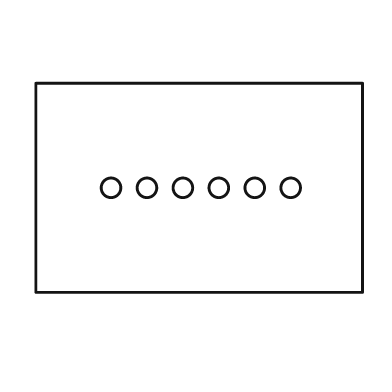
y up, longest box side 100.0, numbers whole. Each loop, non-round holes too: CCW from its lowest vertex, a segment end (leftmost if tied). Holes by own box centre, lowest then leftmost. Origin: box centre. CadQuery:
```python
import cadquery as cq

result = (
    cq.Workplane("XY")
    .moveTo(-50.0, -32.0)
    .lineTo(50.0, -32.0)
    .lineTo(50.0, 32.0)
    .lineTo(-50.0, 32.0)
    .close()
    .moveTo(-27.0, 0.0)
    .circle(3.0)
    .moveTo(-16.0, 0.0)
    .circle(3.0)
    .moveTo(-5.0, 0.0)
    .circle(3.0)
    .moveTo(6.0, 0.0)
    .circle(3.0)
    .moveTo(17.0, 0.0)
    .circle(3.0)
    .moveTo(28.0, 0.0)
    .circle(3.0)
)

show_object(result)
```